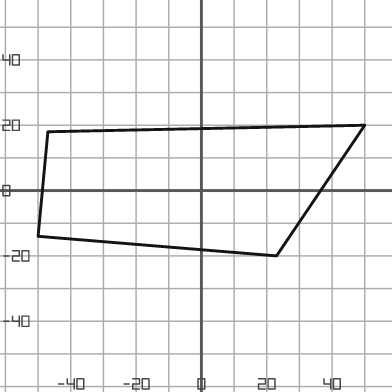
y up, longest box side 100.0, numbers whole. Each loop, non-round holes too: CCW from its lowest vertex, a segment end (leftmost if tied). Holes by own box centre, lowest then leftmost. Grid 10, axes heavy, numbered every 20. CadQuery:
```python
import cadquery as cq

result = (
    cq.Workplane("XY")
    .moveTo(23.0, -20.0)
    .lineTo(50.0, 20.0)
    .lineTo(-47.0, 18.0)
    .lineTo(-50.0, -14.0)
    .close()
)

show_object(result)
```